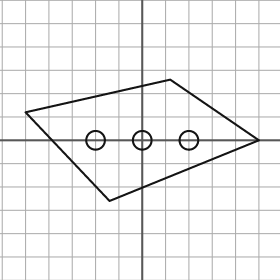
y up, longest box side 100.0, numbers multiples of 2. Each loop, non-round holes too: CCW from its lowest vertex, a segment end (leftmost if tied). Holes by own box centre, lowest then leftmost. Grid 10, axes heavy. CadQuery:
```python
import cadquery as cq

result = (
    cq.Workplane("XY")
    .moveTo(-14.0, -26.0)
    .lineTo(50.0, 0.0)
    .lineTo(12.0, 26.0)
    .lineTo(-50.0, 12.0)
    .close()
    .moveTo(-20.0, 0.0)
    .circle(4.0)
    .moveTo(0.0, 0.0)
    .circle(4.0)
    .moveTo(20.0, 0.0)
    .circle(4.0)
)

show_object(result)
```